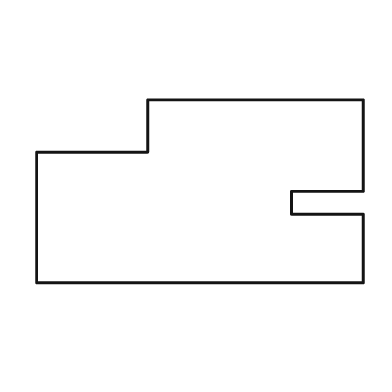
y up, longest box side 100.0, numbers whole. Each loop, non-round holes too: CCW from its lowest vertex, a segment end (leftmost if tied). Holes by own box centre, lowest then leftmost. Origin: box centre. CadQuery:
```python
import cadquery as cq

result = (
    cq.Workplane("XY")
    .moveTo(-50.0, -28.0)
    .lineTo(50.0, -28.0)
    .lineTo(50.0, -7.0)
    .lineTo(28.0, -7.0)
    .lineTo(28.0, 0.0)
    .lineTo(50.0, 0.0)
    .lineTo(50.0, 28.0)
    .lineTo(-16.0, 28.0)
    .lineTo(-16.0, 12.0)
    .lineTo(-50.0, 12.0)
    .close()
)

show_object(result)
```